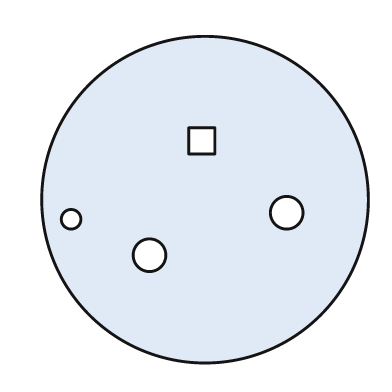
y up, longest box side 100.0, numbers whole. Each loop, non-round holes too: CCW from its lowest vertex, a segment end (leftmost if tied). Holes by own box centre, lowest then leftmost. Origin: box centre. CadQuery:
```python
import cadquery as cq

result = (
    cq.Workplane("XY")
    .moveTo(0.0, 0.0)
    .circle(50.0)
    .moveTo(-17.0, -17.0)
    .circle(5.0)
    .moveTo(-41.0, -6.0)
    .circle(3.0)
    .moveTo(25.0, -4.0)
    .circle(5.0)
    .moveTo(-5.0, 14.0)
    .lineTo(3.0, 14.0)
    .lineTo(3.0, 22.0)
    .lineTo(-5.0, 22.0)
    .close()
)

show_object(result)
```